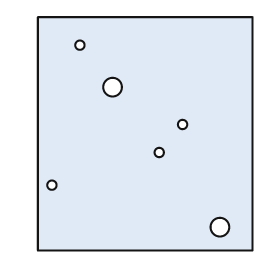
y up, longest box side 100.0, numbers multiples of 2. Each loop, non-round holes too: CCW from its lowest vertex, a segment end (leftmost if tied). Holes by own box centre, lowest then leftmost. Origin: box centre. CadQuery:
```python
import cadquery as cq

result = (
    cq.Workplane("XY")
    .moveTo(-46.0, -50.0)
    .lineTo(46.0, -50.0)
    .lineTo(46.0, 50.0)
    .lineTo(-46.0, 50.0)
    .close()
    .moveTo(32.0, -40.0)
    .circle(4.0)
    .moveTo(-40.0, -22.0)
    .circle(2.0)
    .moveTo(6.0, -8.0)
    .circle(2.0)
    .moveTo(16.0, 4.0)
    .circle(2.0)
    .moveTo(-14.0, 20.0)
    .circle(4.0)
    .moveTo(-28.0, 38.0)
    .circle(2.0)
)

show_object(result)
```